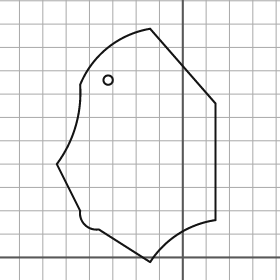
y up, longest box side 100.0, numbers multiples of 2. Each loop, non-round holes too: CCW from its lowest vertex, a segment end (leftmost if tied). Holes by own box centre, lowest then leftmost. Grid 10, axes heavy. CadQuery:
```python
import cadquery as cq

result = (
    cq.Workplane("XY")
    .moveTo(-14.0, -2.0)
    .threePointArc((-2.0, 10.0), (14.0, 16.0))
    .lineTo(14.0, 66.0)
    .lineTo(-14.0, 98.0)
    .threePointArc((-32.0, 90.0), (-44.0, 74.0))
    .threePointArc((-46.0, 56.0), (-54.0, 40.0))
    .lineTo(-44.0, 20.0)
    .threePointArc((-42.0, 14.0), (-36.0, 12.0))
    .close()
    .moveTo(-32.0, 76.0)
    .circle(2.0)
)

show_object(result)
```